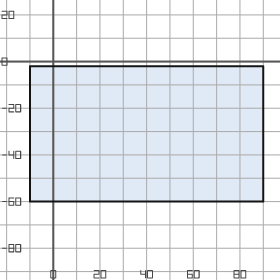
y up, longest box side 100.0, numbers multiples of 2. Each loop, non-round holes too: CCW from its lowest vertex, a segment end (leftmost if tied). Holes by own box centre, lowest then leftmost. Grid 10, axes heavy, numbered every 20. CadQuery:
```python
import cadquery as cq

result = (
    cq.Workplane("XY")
    .moveTo(-10.0, -60.0)
    .lineTo(90.0, -60.0)
    .lineTo(90.0, -2.0)
    .lineTo(-10.0, -2.0)
    .close()
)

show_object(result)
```